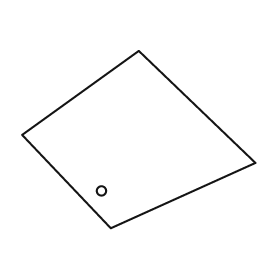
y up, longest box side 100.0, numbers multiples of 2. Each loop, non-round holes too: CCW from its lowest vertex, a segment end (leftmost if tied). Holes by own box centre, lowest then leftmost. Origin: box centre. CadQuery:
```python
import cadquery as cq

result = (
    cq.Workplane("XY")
    .moveTo(-12.0, -38.0)
    .lineTo(50.0, -10.0)
    .lineTo(0.0, 38.0)
    .lineTo(-50.0, 2.0)
    .close()
    .moveTo(-16.0, -22.0)
    .circle(2.0)
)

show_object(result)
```